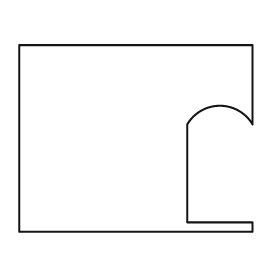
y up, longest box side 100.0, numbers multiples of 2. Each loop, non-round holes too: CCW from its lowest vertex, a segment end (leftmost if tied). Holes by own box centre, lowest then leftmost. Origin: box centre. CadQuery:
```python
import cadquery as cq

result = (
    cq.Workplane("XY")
    .moveTo(-50.0, -40.0)
    .lineTo(50.0, -40.0)
    .lineTo(50.0, -36.0)
    .lineTo(22.0, -36.0)
    .lineTo(22.0, 6.0)
    .threePointArc((36.0, 14.0), (50.0, 6.0))
    .lineTo(50.0, 40.0)
    .lineTo(-50.0, 40.0)
    .close()
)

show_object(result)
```